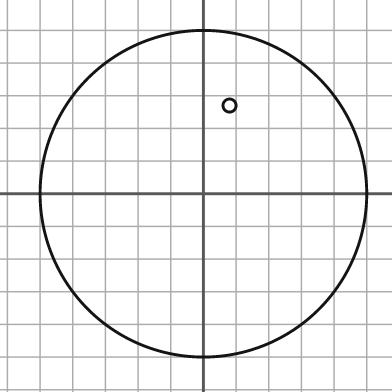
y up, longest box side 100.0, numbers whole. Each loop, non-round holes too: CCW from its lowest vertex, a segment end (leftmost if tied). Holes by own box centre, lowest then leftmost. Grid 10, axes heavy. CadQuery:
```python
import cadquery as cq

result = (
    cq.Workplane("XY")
    .moveTo(0.0, 0.0)
    .circle(50.0)
    .moveTo(8.0, 27.0)
    .circle(2.0)
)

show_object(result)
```